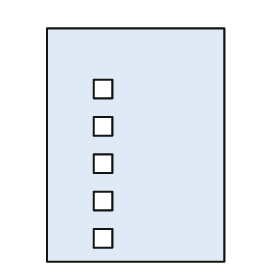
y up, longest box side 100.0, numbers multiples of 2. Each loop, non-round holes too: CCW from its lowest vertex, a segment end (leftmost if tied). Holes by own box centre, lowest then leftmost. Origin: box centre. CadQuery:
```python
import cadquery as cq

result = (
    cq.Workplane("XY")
    .moveTo(-38.0, -50.0)
    .lineTo(38.0, -50.0)
    .lineTo(38.0, 50.0)
    .lineTo(-38.0, 50.0)
    .close()
    .moveTo(-18.0, -44.0)
    .lineTo(-10.0, -44.0)
    .lineTo(-10.0, -36.0)
    .lineTo(-18.0, -36.0)
    .close()
    .moveTo(-18.0, -28.0)
    .lineTo(-10.0, -28.0)
    .lineTo(-10.0, -20.0)
    .lineTo(-18.0, -20.0)
    .close()
    .moveTo(-18.0, -12.0)
    .lineTo(-10.0, -12.0)
    .lineTo(-10.0, -4.0)
    .lineTo(-18.0, -4.0)
    .close()
    .moveTo(-18.0, 4.0)
    .lineTo(-10.0, 4.0)
    .lineTo(-10.0, 12.0)
    .lineTo(-18.0, 12.0)
    .close()
    .moveTo(-18.0, 20.0)
    .lineTo(-10.0, 20.0)
    .lineTo(-10.0, 28.0)
    .lineTo(-18.0, 28.0)
    .close()
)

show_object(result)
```